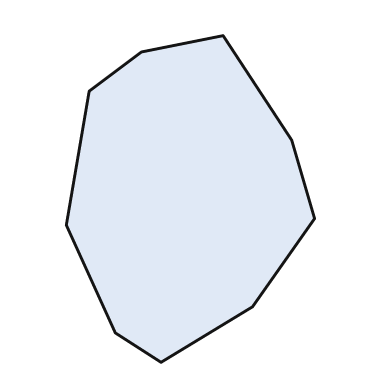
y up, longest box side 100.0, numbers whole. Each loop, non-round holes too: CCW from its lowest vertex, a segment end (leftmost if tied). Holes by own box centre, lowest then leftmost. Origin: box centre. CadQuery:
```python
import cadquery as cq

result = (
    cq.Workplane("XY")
    .moveTo(-9.0, -50.0)
    .lineTo(19.0, -33.0)
    .lineTo(38.0, -6.0)
    .lineTo(31.0, 18.0)
    .lineTo(10.0, 50.0)
    .lineTo(-15.0, 45.0)
    .lineTo(-31.0, 33.0)
    .lineTo(-38.0, -8.0)
    .lineTo(-23.0, -41.0)
    .close()
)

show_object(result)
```